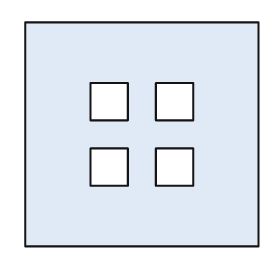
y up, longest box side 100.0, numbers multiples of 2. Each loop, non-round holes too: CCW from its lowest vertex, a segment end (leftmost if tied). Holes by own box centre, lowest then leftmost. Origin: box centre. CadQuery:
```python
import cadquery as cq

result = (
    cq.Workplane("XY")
    .moveTo(-50.0, -48.0)
    .lineTo(50.0, -48.0)
    .lineTo(50.0, 48.0)
    .lineTo(-50.0, 48.0)
    .close()
    .moveTo(-22.0, -22.0)
    .lineTo(-6.0, -22.0)
    .lineTo(-6.0, -6.0)
    .lineTo(-22.0, -6.0)
    .close()
    .moveTo(6.0, -22.0)
    .lineTo(22.0, -22.0)
    .lineTo(22.0, -6.0)
    .lineTo(6.0, -6.0)
    .close()
    .moveTo(-22.0, 6.0)
    .lineTo(-6.0, 6.0)
    .lineTo(-6.0, 22.0)
    .lineTo(-22.0, 22.0)
    .close()
    .moveTo(6.0, 6.0)
    .lineTo(22.0, 6.0)
    .lineTo(22.0, 22.0)
    .lineTo(6.0, 22.0)
    .close()
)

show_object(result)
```